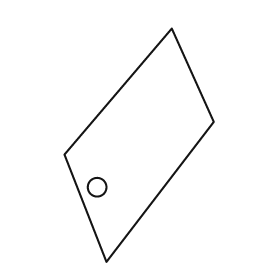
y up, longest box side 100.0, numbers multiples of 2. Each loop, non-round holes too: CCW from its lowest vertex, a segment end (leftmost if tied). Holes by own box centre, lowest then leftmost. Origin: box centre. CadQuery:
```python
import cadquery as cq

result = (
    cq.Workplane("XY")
    .moveTo(-14.0, -50.0)
    .lineTo(32.0, 10.0)
    .lineTo(14.0, 50.0)
    .lineTo(-32.0, -4.0)
    .close()
    .moveTo(-18.0, -18.0)
    .circle(4.0)
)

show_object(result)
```